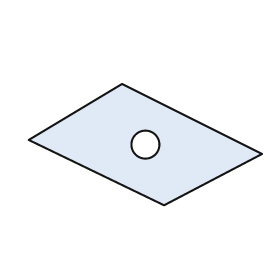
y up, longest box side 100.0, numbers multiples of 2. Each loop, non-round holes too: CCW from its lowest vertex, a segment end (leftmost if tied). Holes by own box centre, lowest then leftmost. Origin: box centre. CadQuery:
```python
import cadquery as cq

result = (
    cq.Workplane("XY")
    .moveTo(8.0, -26.0)
    .lineTo(50.0, -4.0)
    .lineTo(-10.0, 26.0)
    .lineTo(-50.0, 2.0)
    .close()
    .moveTo(0.0, 0.0)
    .circle(6.0)
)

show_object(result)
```